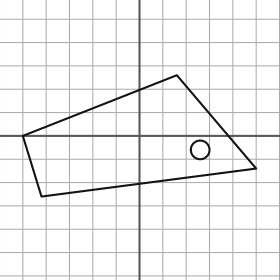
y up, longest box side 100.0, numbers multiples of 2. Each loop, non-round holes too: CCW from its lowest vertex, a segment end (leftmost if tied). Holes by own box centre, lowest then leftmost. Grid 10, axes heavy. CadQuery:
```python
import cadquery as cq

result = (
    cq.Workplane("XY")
    .moveTo(-42.0, -26.0)
    .lineTo(50.0, -14.0)
    .lineTo(16.0, 26.0)
    .lineTo(-50.0, 0.0)
    .close()
    .moveTo(26.0, -6.0)
    .circle(4.0)
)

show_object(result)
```